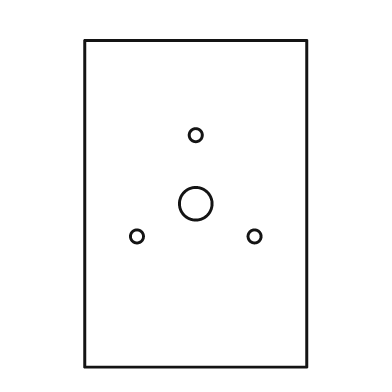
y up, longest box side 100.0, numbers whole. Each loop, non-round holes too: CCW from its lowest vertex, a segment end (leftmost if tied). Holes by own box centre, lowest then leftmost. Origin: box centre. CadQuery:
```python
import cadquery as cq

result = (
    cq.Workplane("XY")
    .moveTo(-34.0, -50.0)
    .lineTo(34.0, -50.0)
    .lineTo(34.0, 50.0)
    .lineTo(-34.0, 50.0)
    .close()
    .moveTo(-18.0, -10.0)
    .circle(2.0)
    .moveTo(18.0, -10.0)
    .circle(2.0)
    .moveTo(0.0, 0.0)
    .circle(5.0)
    .moveTo(0.0, 21.0)
    .circle(2.0)
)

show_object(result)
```